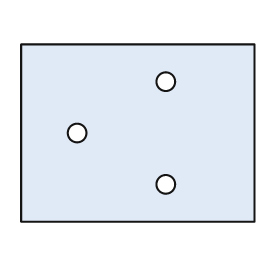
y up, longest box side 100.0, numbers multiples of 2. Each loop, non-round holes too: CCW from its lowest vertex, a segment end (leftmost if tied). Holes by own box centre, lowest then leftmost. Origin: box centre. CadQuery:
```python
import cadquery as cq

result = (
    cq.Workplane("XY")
    .moveTo(-50.0, -38.0)
    .lineTo(50.0, -38.0)
    .lineTo(50.0, 38.0)
    .lineTo(-50.0, 38.0)
    .close()
    .moveTo(12.0, -22.0)
    .circle(4.0)
    .moveTo(-26.0, 0.0)
    .circle(4.0)
    .moveTo(12.0, 22.0)
    .circle(4.0)
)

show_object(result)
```